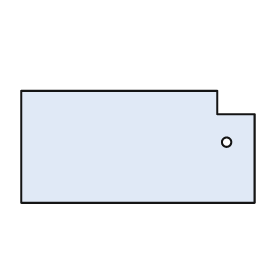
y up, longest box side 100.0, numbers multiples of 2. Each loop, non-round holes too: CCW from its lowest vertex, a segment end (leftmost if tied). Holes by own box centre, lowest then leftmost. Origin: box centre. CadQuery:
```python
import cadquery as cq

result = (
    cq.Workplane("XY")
    .moveTo(-50.0, -24.0)
    .lineTo(50.0, -24.0)
    .lineTo(50.0, 14.0)
    .lineTo(34.0, 14.0)
    .lineTo(34.0, 24.0)
    .lineTo(-50.0, 24.0)
    .close()
    .moveTo(38.0, 2.0)
    .circle(2.0)
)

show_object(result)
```